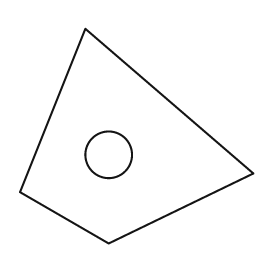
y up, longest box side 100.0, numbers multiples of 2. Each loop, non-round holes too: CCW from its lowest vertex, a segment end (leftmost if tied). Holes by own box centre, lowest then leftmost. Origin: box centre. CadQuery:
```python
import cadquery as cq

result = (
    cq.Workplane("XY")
    .moveTo(-12.0, -46.0)
    .lineTo(50.0, -16.0)
    .lineTo(-22.0, 46.0)
    .lineTo(-50.0, -24.0)
    .close()
    .moveTo(-12.0, -8.0)
    .circle(10.0)
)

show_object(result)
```